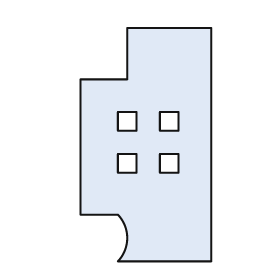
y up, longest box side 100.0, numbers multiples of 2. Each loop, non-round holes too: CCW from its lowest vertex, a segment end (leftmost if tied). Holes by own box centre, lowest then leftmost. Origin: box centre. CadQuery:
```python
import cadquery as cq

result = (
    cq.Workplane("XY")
    .moveTo(-12.0, -50.0)
    .lineTo(28.0, -50.0)
    .lineTo(28.0, 50.0)
    .lineTo(-8.0, 50.0)
    .lineTo(-8.0, 28.0)
    .lineTo(-28.0, 28.0)
    .lineTo(-28.0, -30.0)
    .lineTo(-12.0, -30.0)
    .threePointArc((-8.0, -40.0), (-12.0, -50.0))
    .close()
    .moveTo(-12.0, -12.0)
    .lineTo(-4.0, -12.0)
    .lineTo(-4.0, -4.0)
    .lineTo(-12.0, -4.0)
    .close()
    .moveTo(6.0, -12.0)
    .lineTo(14.0, -12.0)
    .lineTo(14.0, -4.0)
    .lineTo(6.0, -4.0)
    .close()
    .moveTo(-12.0, 6.0)
    .lineTo(-4.0, 6.0)
    .lineTo(-4.0, 14.0)
    .lineTo(-12.0, 14.0)
    .close()
    .moveTo(6.0, 6.0)
    .lineTo(14.0, 6.0)
    .lineTo(14.0, 14.0)
    .lineTo(6.0, 14.0)
    .close()
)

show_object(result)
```